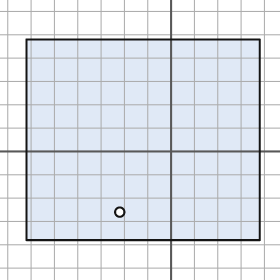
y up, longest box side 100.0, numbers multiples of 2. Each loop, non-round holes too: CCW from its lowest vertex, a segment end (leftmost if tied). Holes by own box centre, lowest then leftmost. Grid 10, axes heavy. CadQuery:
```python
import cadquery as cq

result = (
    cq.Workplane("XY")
    .moveTo(-62.0, -38.0)
    .lineTo(38.0, -38.0)
    .lineTo(38.0, 48.0)
    .lineTo(-62.0, 48.0)
    .close()
    .moveTo(-22.0, -26.0)
    .circle(2.0)
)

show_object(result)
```